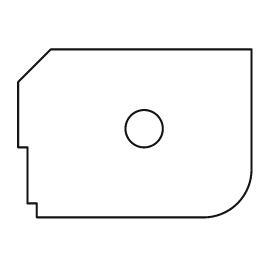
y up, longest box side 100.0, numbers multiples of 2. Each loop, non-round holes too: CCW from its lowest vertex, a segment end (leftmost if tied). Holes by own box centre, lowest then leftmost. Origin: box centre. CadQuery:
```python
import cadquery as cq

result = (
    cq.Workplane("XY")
    .moveTo(-42.0, -36.0)
    .lineTo(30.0, -36.0)
    .threePointArc((44.0, -30.0), (50.0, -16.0))
    .lineTo(50.0, 36.0)
    .lineTo(-36.0, 36.0)
    .lineTo(-50.0, 22.0)
    .lineTo(-50.0, -6.0)
    .lineTo(-46.0, -6.0)
    .lineTo(-46.0, -30.0)
    .lineTo(-42.0, -30.0)
    .close()
    .moveTo(4.0, 2.0)
    .circle(8.0)
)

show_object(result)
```